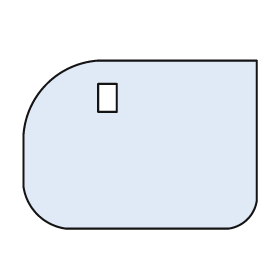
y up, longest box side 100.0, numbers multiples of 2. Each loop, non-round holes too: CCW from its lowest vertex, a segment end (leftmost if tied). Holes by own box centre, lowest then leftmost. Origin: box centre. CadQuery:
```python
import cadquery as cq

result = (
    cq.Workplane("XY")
    .moveTo(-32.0, -36.0)
    .lineTo(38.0, -36.0)
    .threePointArc((46.0, -32.0), (50.0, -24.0))
    .lineTo(50.0, 36.0)
    .lineTo(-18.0, 36.0)
    .threePointArc((-40.0, 26.0), (-50.0, 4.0))
    .lineTo(-50.0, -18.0)
    .threePointArc((-44.0, -30.0), (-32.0, -36.0))
    .close()
    .moveTo(-18.0, 14.0)
    .lineTo(-10.0, 14.0)
    .lineTo(-10.0, 26.0)
    .lineTo(-18.0, 26.0)
    .close()
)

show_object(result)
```